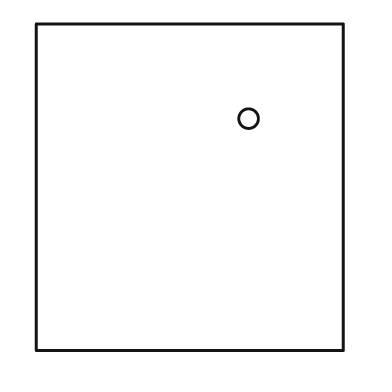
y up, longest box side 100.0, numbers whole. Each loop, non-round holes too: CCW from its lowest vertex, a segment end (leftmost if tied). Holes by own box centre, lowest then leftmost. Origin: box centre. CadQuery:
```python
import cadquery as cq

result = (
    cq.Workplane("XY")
    .moveTo(-47.0, -50.0)
    .lineTo(47.0, -50.0)
    .lineTo(47.0, 50.0)
    .lineTo(-47.0, 50.0)
    .close()
    .moveTo(18.0, 21.0)
    .circle(3.0)
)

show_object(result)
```